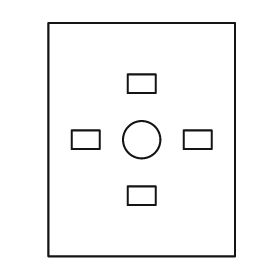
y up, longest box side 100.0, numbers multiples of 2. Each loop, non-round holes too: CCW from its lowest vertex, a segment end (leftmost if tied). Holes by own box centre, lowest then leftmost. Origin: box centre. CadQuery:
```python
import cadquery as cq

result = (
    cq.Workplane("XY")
    .moveTo(-40.0, -50.0)
    .lineTo(40.0, -50.0)
    .lineTo(40.0, 50.0)
    .lineTo(-40.0, 50.0)
    .close()
    .moveTo(-6.0, -28.0)
    .lineTo(6.0, -28.0)
    .lineTo(6.0, -20.0)
    .lineTo(-6.0, -20.0)
    .close()
    .moveTo(-30.0, -4.0)
    .lineTo(-18.0, -4.0)
    .lineTo(-18.0, 4.0)
    .lineTo(-30.0, 4.0)
    .close()
    .moveTo(0.0, 0.0)
    .circle(8.0)
    .moveTo(18.0, -4.0)
    .lineTo(30.0, -4.0)
    .lineTo(30.0, 4.0)
    .lineTo(18.0, 4.0)
    .close()
    .moveTo(-6.0, 20.0)
    .lineTo(6.0, 20.0)
    .lineTo(6.0, 28.0)
    .lineTo(-6.0, 28.0)
    .close()
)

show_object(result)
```